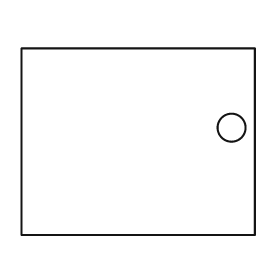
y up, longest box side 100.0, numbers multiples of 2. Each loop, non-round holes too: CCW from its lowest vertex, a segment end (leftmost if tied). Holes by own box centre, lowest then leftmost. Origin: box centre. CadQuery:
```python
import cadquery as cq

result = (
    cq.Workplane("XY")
    .moveTo(-50.0, -40.0)
    .lineTo(50.0, -40.0)
    .lineTo(50.0, 40.0)
    .lineTo(-50.0, 40.0)
    .close()
    .moveTo(40.0, 6.0)
    .circle(6.0)
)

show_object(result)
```